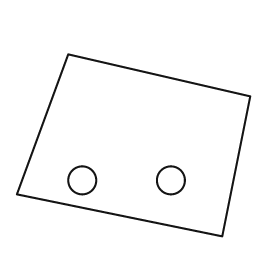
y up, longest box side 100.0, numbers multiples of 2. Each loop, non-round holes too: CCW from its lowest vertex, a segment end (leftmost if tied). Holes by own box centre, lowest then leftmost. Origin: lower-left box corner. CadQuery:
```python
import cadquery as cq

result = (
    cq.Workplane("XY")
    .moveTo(88.0, 0.0)
    .lineTo(100.0, 60.0)
    .lineTo(22.0, 78.0)
    .lineTo(0.0, 18.0)
    .close()
    .moveTo(28.0, 24.0)
    .circle(6.0)
    .moveTo(66.0, 24.0)
    .circle(6.0)
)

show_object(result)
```